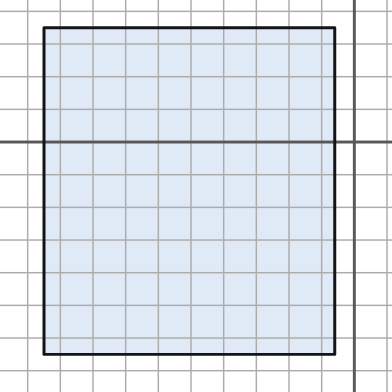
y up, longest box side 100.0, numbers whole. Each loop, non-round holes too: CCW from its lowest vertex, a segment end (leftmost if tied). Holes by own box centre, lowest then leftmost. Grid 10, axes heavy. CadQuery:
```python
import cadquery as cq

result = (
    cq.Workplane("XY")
    .moveTo(-95.0, -65.0)
    .lineTo(-6.0, -65.0)
    .lineTo(-6.0, 35.0)
    .lineTo(-95.0, 35.0)
    .close()
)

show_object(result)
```